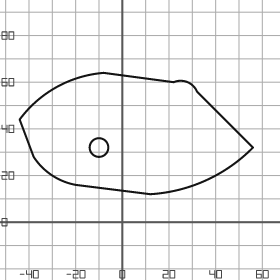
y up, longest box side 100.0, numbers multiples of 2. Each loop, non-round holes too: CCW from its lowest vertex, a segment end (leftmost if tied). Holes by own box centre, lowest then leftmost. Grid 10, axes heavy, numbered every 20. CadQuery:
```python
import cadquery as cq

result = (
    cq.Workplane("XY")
    .moveTo(12.0, 12.0)
    .threePointArc((36.0, 18.0), (56.0, 32.0))
    .lineTo(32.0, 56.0)
    .threePointArc((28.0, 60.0), (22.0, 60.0))
    .lineTo(-8.0, 64.0)
    .threePointArc((-28.0, 58.0), (-44.0, 44.0))
    .lineTo(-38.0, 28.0)
    .threePointArc((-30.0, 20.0), (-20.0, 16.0))
    .close()
    .moveTo(-10.0, 32.0)
    .circle(4.0)
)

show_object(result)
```